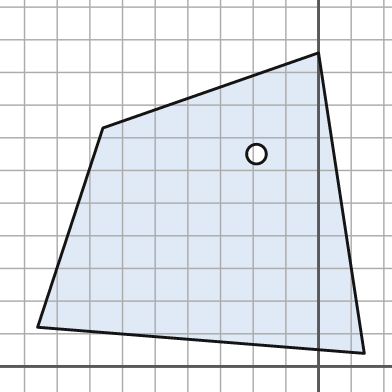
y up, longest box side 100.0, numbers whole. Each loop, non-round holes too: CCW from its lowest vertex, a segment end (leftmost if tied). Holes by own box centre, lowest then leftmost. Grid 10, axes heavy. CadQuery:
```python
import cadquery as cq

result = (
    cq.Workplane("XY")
    .moveTo(14.0, 4.0)
    .lineTo(0.0, 96.0)
    .lineTo(-66.0, 73.0)
    .lineTo(-86.0, 12.0)
    .close()
    .moveTo(-19.0, 65.0)
    .circle(3.0)
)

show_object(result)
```